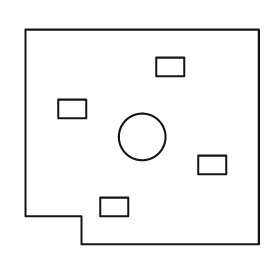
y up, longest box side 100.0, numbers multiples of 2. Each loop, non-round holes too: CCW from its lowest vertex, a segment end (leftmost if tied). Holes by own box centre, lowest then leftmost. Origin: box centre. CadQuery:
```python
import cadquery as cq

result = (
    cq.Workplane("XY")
    .moveTo(-26.0, -46.0)
    .lineTo(50.0, -46.0)
    .lineTo(50.0, 46.0)
    .lineTo(-50.0, 46.0)
    .lineTo(-50.0, -34.0)
    .lineTo(-26.0, -34.0)
    .close()
    .moveTo(-18.0, -34.0)
    .lineTo(-6.0, -34.0)
    .lineTo(-6.0, -26.0)
    .lineTo(-18.0, -26.0)
    .close()
    .moveTo(24.0, -16.0)
    .lineTo(36.0, -16.0)
    .lineTo(36.0, -8.0)
    .lineTo(24.0, -8.0)
    .close()
    .moveTo(0.0, 0.0)
    .circle(10.0)
    .moveTo(-36.0, 8.0)
    .lineTo(-24.0, 8.0)
    .lineTo(-24.0, 16.0)
    .lineTo(-36.0, 16.0)
    .close()
    .moveTo(6.0, 26.0)
    .lineTo(18.0, 26.0)
    .lineTo(18.0, 34.0)
    .lineTo(6.0, 34.0)
    .close()
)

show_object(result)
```